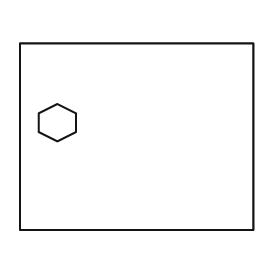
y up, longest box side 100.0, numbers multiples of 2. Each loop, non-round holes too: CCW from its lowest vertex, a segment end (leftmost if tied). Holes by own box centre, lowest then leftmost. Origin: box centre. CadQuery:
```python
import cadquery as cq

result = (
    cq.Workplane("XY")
    .moveTo(-50.0, -40.0)
    .lineTo(50.0, -40.0)
    .lineTo(50.0, 40.0)
    .lineTo(-50.0, 40.0)
    .close()
    .moveTo(-34.0, -2.0)
    .lineTo(-26.0, 2.0)
    .lineTo(-26.0, 10.0)
    .lineTo(-34.0, 14.0)
    .lineTo(-42.0, 10.0)
    .lineTo(-42.0, 2.0)
    .close()
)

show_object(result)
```